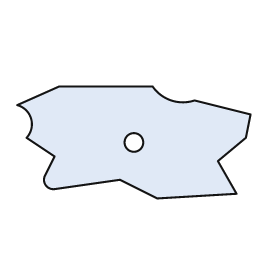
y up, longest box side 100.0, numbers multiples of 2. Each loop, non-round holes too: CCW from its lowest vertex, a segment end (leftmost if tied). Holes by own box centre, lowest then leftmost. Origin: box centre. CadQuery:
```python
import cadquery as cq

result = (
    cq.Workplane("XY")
    .moveTo(10.0, -24.0)
    .lineTo(44.0, -22.0)
    .lineTo(36.0, -8.0)
    .lineTo(48.0, 2.0)
    .lineTo(50.0, 12.0)
    .lineTo(26.0, 18.0)
    .threePointArc((16.0, 18.0), (8.0, 24.0))
    .lineTo(-32.0, 24.0)
    .lineTo(-50.0, 16.0)
    .threePointArc((-44.0, 10.0), (-46.0, 2.0))
    .lineTo(-34.0, -6.0)
    .lineTo(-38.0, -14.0)
    .threePointArc((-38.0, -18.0), (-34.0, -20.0))
    .lineTo(-6.0, -16.0)
    .close()
    .moveTo(0.0, 0.0)
    .circle(4.0)
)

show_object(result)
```